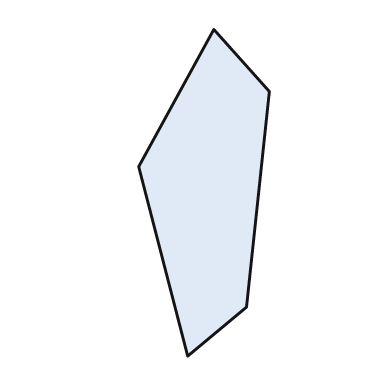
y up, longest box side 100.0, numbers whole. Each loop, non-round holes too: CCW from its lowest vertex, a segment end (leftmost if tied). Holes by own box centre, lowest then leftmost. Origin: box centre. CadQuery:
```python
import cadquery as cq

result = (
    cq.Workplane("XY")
    .moveTo(-5.0, -50.0)
    .lineTo(13.0, -35.0)
    .lineTo(20.0, 31.0)
    .lineTo(3.0, 50.0)
    .lineTo(-20.0, 8.0)
    .close()
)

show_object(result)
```